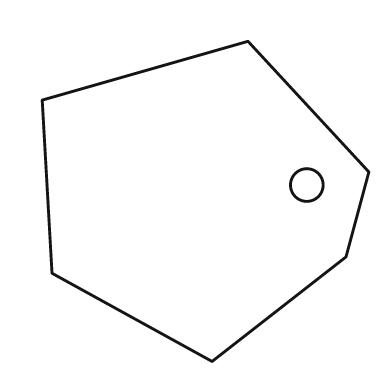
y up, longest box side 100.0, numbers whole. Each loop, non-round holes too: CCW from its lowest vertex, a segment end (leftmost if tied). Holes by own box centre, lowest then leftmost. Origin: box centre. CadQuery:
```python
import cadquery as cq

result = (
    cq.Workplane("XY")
    .moveTo(2.0, -49.0)
    .lineTo(43.0, -17.0)
    .lineTo(50.0, 9.0)
    .lineTo(13.0, 49.0)
    .lineTo(-50.0, 31.0)
    .lineTo(-47.0, -22.0)
    .close()
    .moveTo(31.0, 5.0)
    .circle(5.0)
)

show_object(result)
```